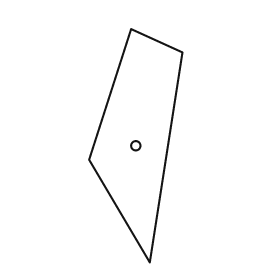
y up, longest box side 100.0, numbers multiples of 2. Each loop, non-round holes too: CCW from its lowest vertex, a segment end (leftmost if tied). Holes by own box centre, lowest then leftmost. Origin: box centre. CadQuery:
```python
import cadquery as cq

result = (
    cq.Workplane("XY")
    .moveTo(6.0, -50.0)
    .lineTo(20.0, 40.0)
    .lineTo(-2.0, 50.0)
    .lineTo(-20.0, -6.0)
    .close()
    .moveTo(0.0, 0.0)
    .circle(2.0)
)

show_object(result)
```